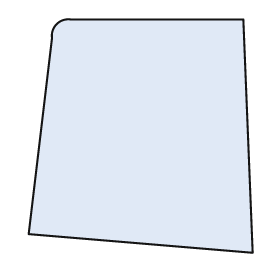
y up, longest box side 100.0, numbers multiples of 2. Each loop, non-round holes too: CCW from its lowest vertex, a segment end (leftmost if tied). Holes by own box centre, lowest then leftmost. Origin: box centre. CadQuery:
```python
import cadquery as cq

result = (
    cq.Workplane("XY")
    .moveTo(48.0, -50.0)
    .lineTo(44.0, 50.0)
    .lineTo(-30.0, 50.0)
    .threePointArc((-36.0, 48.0), (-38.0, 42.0))
    .lineTo(-48.0, -42.0)
    .close()
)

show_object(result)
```